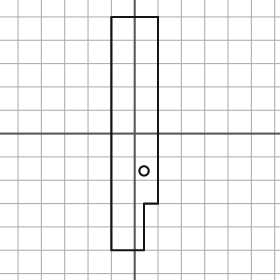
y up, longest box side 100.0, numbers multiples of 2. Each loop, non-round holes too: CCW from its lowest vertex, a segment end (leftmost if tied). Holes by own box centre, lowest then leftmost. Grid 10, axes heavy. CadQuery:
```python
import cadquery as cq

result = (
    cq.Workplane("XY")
    .moveTo(-10.0, -50.0)
    .lineTo(4.0, -50.0)
    .lineTo(4.0, -30.0)
    .lineTo(10.0, -30.0)
    .lineTo(10.0, 50.0)
    .lineTo(-10.0, 50.0)
    .close()
    .moveTo(4.0, -16.0)
    .circle(2.0)
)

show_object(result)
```